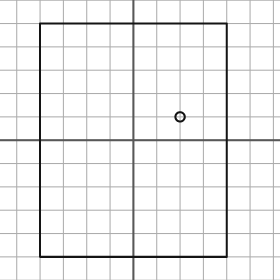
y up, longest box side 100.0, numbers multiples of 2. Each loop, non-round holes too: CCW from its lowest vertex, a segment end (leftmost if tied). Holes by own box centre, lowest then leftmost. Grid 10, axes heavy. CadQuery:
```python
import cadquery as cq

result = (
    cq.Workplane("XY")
    .moveTo(-40.0, -50.0)
    .lineTo(40.0, -50.0)
    .lineTo(40.0, 50.0)
    .lineTo(-40.0, 50.0)
    .close()
    .moveTo(20.0, 10.0)
    .circle(2.0)
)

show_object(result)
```